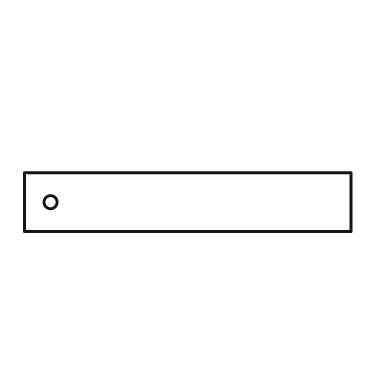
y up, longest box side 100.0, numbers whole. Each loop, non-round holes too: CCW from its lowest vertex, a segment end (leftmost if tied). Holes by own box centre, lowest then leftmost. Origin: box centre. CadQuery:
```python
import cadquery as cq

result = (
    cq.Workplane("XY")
    .moveTo(-50.0, -9.0)
    .lineTo(50.0, -9.0)
    .lineTo(50.0, 9.0)
    .lineTo(-50.0, 9.0)
    .close()
    .moveTo(-42.0, 0.0)
    .circle(2.0)
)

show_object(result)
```